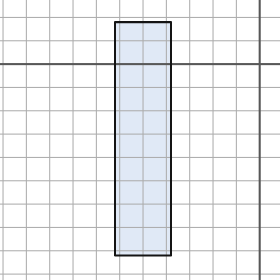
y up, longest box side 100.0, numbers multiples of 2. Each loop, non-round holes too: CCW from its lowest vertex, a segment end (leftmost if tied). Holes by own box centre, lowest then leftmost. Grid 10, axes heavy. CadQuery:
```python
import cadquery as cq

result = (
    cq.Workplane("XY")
    .moveTo(-62.0, -82.0)
    .lineTo(-38.0, -82.0)
    .lineTo(-38.0, 18.0)
    .lineTo(-62.0, 18.0)
    .close()
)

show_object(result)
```